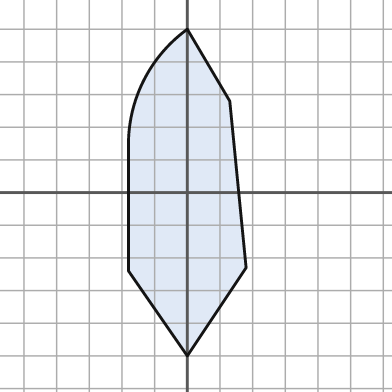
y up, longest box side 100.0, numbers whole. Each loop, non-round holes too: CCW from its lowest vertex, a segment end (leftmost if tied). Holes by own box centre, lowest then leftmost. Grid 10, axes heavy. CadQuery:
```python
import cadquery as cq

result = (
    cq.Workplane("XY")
    .moveTo(0.0, -50.0)
    .lineTo(18.0, -23.0)
    .lineTo(13.0, 28.0)
    .lineTo(0.0, 50.0)
    .threePointArc((-13.0, 35.0), (-18.0, 16.0))
    .lineTo(-18.0, -24.0)
    .close()
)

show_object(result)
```